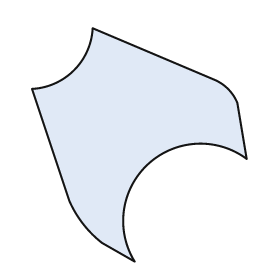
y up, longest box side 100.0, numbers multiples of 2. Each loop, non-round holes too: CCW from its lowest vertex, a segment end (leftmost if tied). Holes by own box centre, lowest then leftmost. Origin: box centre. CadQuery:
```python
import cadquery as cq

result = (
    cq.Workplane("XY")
    .moveTo(-2.0, -50.0)
    .threePointArc((4.0, -8.0), (46.0, -6.0))
    .lineTo(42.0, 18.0)
    .threePointArc((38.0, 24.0), (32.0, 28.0))
    .lineTo(-20.0, 50.0)
    .threePointArc((-28.0, 32.0), (-46.0, 24.0))
    .lineTo(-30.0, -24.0)
    .threePointArc((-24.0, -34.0), (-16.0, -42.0))
    .close()
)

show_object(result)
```